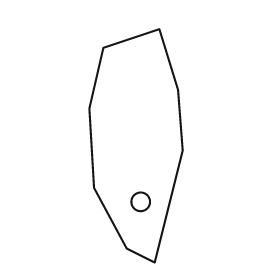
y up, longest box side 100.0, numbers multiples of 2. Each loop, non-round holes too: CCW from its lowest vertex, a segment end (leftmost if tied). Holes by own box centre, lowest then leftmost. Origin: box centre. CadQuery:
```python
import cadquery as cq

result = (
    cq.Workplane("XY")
    .moveTo(8.0, -50.0)
    .lineTo(20.0, -2.0)
    .lineTo(18.0, 24.0)
    .lineTo(10.0, 50.0)
    .lineTo(-14.0, 42.0)
    .lineTo(-20.0, 16.0)
    .lineTo(-18.0, -18.0)
    .lineTo(-4.0, -44.0)
    .close()
    .moveTo(2.0, -24.0)
    .circle(4.0)
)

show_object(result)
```